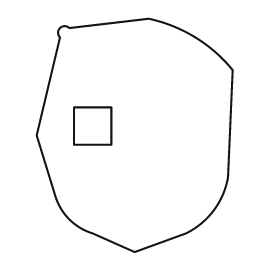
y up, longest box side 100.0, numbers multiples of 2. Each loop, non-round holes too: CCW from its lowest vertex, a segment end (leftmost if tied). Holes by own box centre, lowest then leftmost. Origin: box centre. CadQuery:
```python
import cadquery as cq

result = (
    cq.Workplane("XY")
    .moveTo(0.0, -50.0)
    .lineTo(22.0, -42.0)
    .threePointArc((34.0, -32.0), (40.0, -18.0))
    .lineTo(42.0, 28.0)
    .threePointArc((26.0, 42.0), (6.0, 50.0))
    .lineTo(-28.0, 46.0)
    .threePointArc((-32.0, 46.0), (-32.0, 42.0))
    .lineTo(-42.0, 0.0)
    .lineTo(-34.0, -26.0)
    .threePointArc((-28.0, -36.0), (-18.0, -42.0))
    .close()
    .moveTo(-26.0, -4.0)
    .lineTo(-10.0, -4.0)
    .lineTo(-10.0, 12.0)
    .lineTo(-26.0, 12.0)
    .close()
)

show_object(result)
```